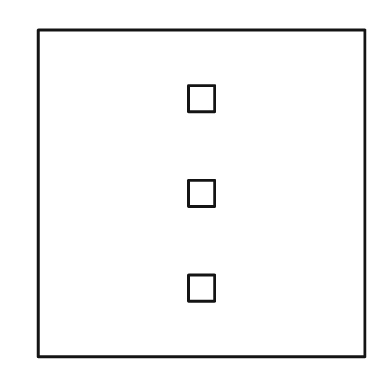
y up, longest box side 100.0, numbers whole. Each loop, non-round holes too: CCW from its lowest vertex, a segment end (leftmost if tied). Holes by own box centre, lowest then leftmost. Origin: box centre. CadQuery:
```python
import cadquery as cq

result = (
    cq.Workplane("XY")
    .moveTo(-50.0, -50.0)
    .lineTo(50.0, -50.0)
    .lineTo(50.0, 50.0)
    .lineTo(-50.0, 50.0)
    .close()
    .moveTo(-4.0, -33.0)
    .lineTo(4.0, -33.0)
    .lineTo(4.0, -25.0)
    .lineTo(-4.0, -25.0)
    .close()
    .moveTo(-4.0, -4.0)
    .lineTo(4.0, -4.0)
    .lineTo(4.0, 4.0)
    .lineTo(-4.0, 4.0)
    .close()
    .moveTo(-4.0, 25.0)
    .lineTo(4.0, 25.0)
    .lineTo(4.0, 33.0)
    .lineTo(-4.0, 33.0)
    .close()
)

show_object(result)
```